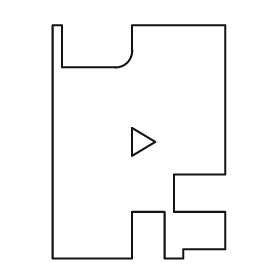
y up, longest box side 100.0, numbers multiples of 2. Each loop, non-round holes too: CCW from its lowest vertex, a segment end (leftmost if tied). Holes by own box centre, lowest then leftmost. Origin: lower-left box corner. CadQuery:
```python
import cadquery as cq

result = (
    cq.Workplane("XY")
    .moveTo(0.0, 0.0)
    .lineTo(34.0, 0.0)
    .lineTo(34.0, 20.0)
    .lineTo(48.0, 20.0)
    .lineTo(48.0, 0.0)
    .lineTo(56.0, 0.0)
    .lineTo(56.0, 4.0)
    .lineTo(74.0, 4.0)
    .lineTo(74.0, 20.0)
    .lineTo(52.0, 20.0)
    .lineTo(52.0, 36.0)
    .lineTo(74.0, 36.0)
    .lineTo(74.0, 100.0)
    .lineTo(34.0, 100.0)
    .lineTo(34.0, 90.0)
    .threePointArc((32.0, 84.0), (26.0, 82.0))
    .lineTo(4.0, 82.0)
    .lineTo(4.0, 100.0)
    .lineTo(0.0, 100.0)
    .close()
    .moveTo(34.0, 44.0)
    .lineTo(44.0, 50.0)
    .lineTo(34.0, 56.0)
    .close()
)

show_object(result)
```